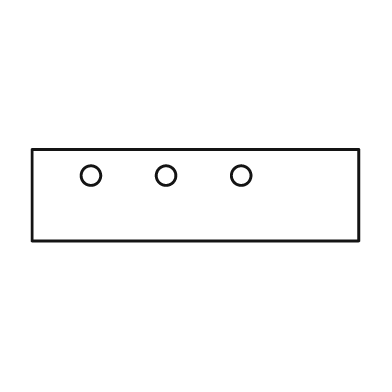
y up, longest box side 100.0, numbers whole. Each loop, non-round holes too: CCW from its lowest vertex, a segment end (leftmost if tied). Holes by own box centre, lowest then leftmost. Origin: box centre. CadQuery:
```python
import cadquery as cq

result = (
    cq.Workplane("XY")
    .moveTo(-50.0, -14.0)
    .lineTo(50.0, -14.0)
    .lineTo(50.0, 14.0)
    .lineTo(-50.0, 14.0)
    .close()
    .moveTo(-32.0, 6.0)
    .circle(3.0)
    .moveTo(-9.0, 6.0)
    .circle(3.0)
    .moveTo(14.0, 6.0)
    .circle(3.0)
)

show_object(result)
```